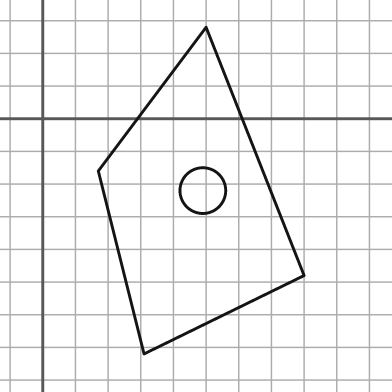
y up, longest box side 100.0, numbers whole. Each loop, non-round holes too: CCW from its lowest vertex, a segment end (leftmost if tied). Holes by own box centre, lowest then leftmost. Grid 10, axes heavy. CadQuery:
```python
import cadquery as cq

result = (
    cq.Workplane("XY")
    .moveTo(31.0, -72.0)
    .lineTo(80.0, -48.0)
    .lineTo(50.0, 28.0)
    .lineTo(17.0, -16.0)
    .close()
    .moveTo(49.0, -22.0)
    .circle(7.0)
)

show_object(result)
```